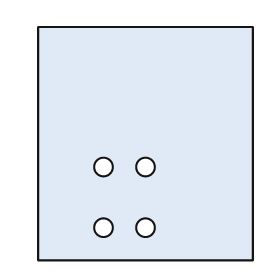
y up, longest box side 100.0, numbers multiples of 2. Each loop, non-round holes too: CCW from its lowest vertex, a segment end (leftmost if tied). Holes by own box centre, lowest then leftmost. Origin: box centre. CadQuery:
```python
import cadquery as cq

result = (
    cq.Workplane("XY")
    .moveTo(-46.0, -50.0)
    .lineTo(46.0, -50.0)
    .lineTo(46.0, 50.0)
    .lineTo(-46.0, 50.0)
    .close()
    .moveTo(-18.0, -36.0)
    .circle(4.0)
    .moveTo(0.0, -36.0)
    .circle(4.0)
    .moveTo(-18.0, -10.0)
    .circle(4.0)
    .moveTo(0.0, -10.0)
    .circle(4.0)
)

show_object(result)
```